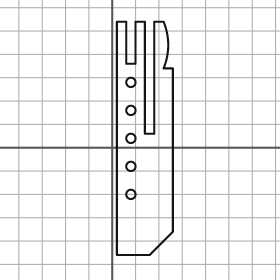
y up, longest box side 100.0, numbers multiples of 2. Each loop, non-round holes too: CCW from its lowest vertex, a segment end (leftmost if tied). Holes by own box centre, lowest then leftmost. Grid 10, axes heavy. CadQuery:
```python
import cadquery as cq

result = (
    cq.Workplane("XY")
    .moveTo(2.0, -46.0)
    .lineTo(16.0, -46.0)
    .lineTo(26.0, -36.0)
    .lineTo(26.0, 34.0)
    .lineTo(22.0, 34.0)
    .threePointArc((24.0, 44.0), (22.0, 54.0))
    .lineTo(18.0, 54.0)
    .lineTo(18.0, 6.0)
    .lineTo(14.0, 6.0)
    .lineTo(14.0, 54.0)
    .lineTo(10.0, 54.0)
    .lineTo(10.0, 36.0)
    .lineTo(6.0, 36.0)
    .lineTo(6.0, 54.0)
    .lineTo(2.0, 54.0)
    .close()
    .moveTo(8.0, -20.0)
    .circle(2.0)
    .moveTo(8.0, -8.0)
    .circle(2.0)
    .moveTo(8.0, 4.0)
    .circle(2.0)
    .moveTo(8.0, 16.0)
    .circle(2.0)
    .moveTo(8.0, 28.0)
    .circle(2.0)
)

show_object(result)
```